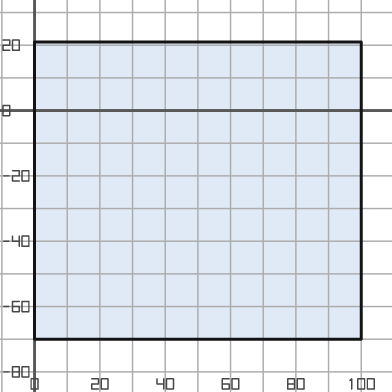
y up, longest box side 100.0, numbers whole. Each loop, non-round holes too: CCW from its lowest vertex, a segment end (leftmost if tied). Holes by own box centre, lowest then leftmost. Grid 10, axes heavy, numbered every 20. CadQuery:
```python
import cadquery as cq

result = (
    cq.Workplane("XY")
    .moveTo(0.0, -70.0)
    .lineTo(100.0, -70.0)
    .lineTo(100.0, 21.0)
    .lineTo(0.0, 21.0)
    .close()
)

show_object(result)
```